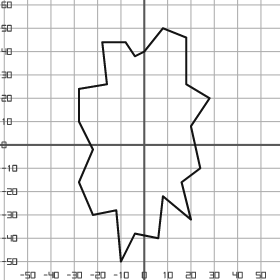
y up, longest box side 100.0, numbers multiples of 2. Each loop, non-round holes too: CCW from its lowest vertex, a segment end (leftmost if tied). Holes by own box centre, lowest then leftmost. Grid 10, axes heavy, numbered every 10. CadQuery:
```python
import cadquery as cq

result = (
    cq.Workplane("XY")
    .moveTo(-10.0, -50.0)
    .lineTo(-4.0, -38.0)
    .lineTo(6.0, -40.0)
    .lineTo(8.0, -22.0)
    .lineTo(20.0, -32.0)
    .lineTo(16.0, -16.0)
    .lineTo(24.0, -10.0)
    .lineTo(20.0, 8.0)
    .lineTo(28.0, 20.0)
    .lineTo(18.0, 26.0)
    .lineTo(18.0, 46.0)
    .lineTo(8.0, 50.0)
    .lineTo(0.0, 40.0)
    .lineTo(-4.0, 38.0)
    .lineTo(-8.0, 44.0)
    .lineTo(-18.0, 44.0)
    .lineTo(-16.0, 26.0)
    .lineTo(-28.0, 24.0)
    .lineTo(-28.0, 10.0)
    .lineTo(-22.0, -2.0)
    .lineTo(-28.0, -16.0)
    .lineTo(-22.0, -30.0)
    .lineTo(-12.0, -28.0)
    .close()
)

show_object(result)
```